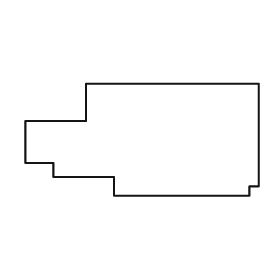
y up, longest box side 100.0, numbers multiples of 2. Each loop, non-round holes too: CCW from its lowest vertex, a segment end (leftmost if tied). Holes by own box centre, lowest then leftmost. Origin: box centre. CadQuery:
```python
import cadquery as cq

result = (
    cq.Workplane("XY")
    .moveTo(-12.0, -24.0)
    .lineTo(46.0, -24.0)
    .lineTo(46.0, -20.0)
    .lineTo(50.0, -20.0)
    .lineTo(50.0, 24.0)
    .lineTo(-24.0, 24.0)
    .lineTo(-24.0, 8.0)
    .lineTo(-50.0, 8.0)
    .lineTo(-50.0, -10.0)
    .lineTo(-38.0, -10.0)
    .lineTo(-38.0, -16.0)
    .lineTo(-12.0, -16.0)
    .close()
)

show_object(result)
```